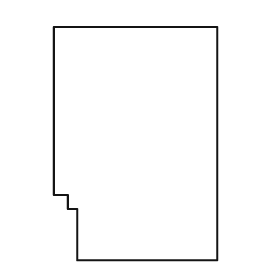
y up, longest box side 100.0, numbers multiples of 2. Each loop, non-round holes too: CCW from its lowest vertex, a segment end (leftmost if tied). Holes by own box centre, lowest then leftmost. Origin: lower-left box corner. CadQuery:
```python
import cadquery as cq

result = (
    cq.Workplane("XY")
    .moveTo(10.0, 0.0)
    .lineTo(70.0, 0.0)
    .lineTo(70.0, 100.0)
    .lineTo(0.0, 100.0)
    .lineTo(0.0, 28.0)
    .lineTo(6.0, 28.0)
    .lineTo(6.0, 22.0)
    .lineTo(10.0, 22.0)
    .close()
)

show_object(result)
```